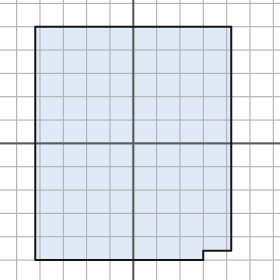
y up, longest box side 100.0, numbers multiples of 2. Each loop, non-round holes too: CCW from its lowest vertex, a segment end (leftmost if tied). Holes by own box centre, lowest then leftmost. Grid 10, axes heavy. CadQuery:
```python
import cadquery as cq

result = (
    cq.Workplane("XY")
    .moveTo(-42.0, -50.0)
    .lineTo(30.0, -50.0)
    .lineTo(30.0, -46.0)
    .lineTo(42.0, -46.0)
    .lineTo(42.0, 50.0)
    .lineTo(-42.0, 50.0)
    .close()
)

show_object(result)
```